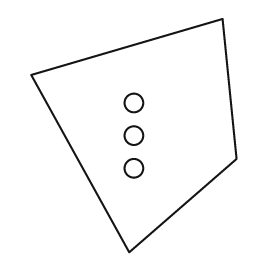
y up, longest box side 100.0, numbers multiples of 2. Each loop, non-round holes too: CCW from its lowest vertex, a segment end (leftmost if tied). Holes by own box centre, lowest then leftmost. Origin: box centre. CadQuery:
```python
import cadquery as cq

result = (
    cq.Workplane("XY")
    .moveTo(-2.0, -50.0)
    .lineTo(44.0, -10.0)
    .lineTo(38.0, 50.0)
    .lineTo(-44.0, 26.0)
    .close()
    .moveTo(0.0, -14.0)
    .circle(4.0)
    .moveTo(0.0, 0.0)
    .circle(4.0)
    .moveTo(0.0, 14.0)
    .circle(4.0)
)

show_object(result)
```